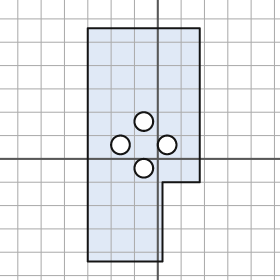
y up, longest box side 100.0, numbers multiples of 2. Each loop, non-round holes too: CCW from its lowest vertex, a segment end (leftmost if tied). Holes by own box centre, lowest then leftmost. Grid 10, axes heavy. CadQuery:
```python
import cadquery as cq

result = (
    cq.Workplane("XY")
    .moveTo(-30.0, -44.0)
    .lineTo(2.0, -44.0)
    .lineTo(2.0, -10.0)
    .lineTo(18.0, -10.0)
    .lineTo(18.0, 56.0)
    .lineTo(-30.0, 56.0)
    .close()
    .moveTo(-6.0, -4.0)
    .circle(4.0)
    .moveTo(-16.0, 6.0)
    .circle(4.0)
    .moveTo(4.0, 6.0)
    .circle(4.0)
    .moveTo(-6.0, 16.0)
    .circle(4.0)
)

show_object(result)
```